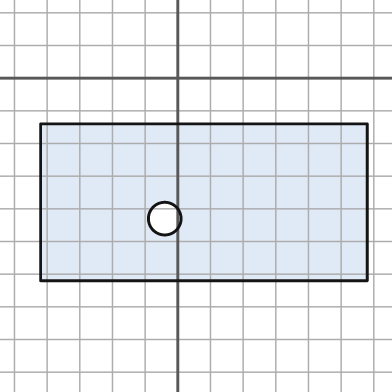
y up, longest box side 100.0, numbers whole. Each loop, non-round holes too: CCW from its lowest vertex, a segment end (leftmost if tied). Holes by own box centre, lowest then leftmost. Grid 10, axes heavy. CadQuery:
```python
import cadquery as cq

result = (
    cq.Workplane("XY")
    .moveTo(-42.0, -62.0)
    .lineTo(58.0, -62.0)
    .lineTo(58.0, -14.0)
    .lineTo(-42.0, -14.0)
    .close()
    .moveTo(-4.0, -43.0)
    .circle(5.0)
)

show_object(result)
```